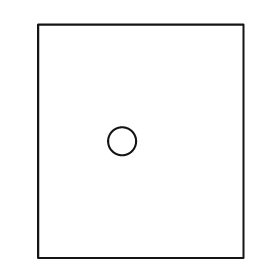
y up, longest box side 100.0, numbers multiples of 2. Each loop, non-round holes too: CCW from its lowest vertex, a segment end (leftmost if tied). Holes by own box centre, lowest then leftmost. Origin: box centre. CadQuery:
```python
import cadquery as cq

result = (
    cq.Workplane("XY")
    .moveTo(-44.0, -50.0)
    .lineTo(44.0, -50.0)
    .lineTo(44.0, 50.0)
    .lineTo(-44.0, 50.0)
    .close()
    .moveTo(-8.0, 0.0)
    .circle(6.0)
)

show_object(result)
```